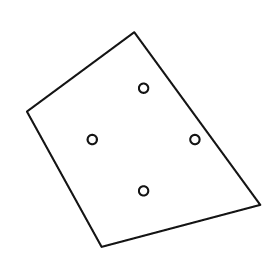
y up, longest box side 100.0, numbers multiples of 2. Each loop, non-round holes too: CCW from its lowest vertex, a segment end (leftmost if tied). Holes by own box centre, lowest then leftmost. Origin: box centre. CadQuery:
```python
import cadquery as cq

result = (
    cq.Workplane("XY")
    .moveTo(-18.0, -46.0)
    .lineTo(50.0, -28.0)
    .lineTo(-4.0, 46.0)
    .lineTo(-50.0, 12.0)
    .close()
    .moveTo(0.0, -22.0)
    .circle(2.0)
    .moveTo(-22.0, 0.0)
    .circle(2.0)
    .moveTo(22.0, 0.0)
    .circle(2.0)
    .moveTo(0.0, 22.0)
    .circle(2.0)
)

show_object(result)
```